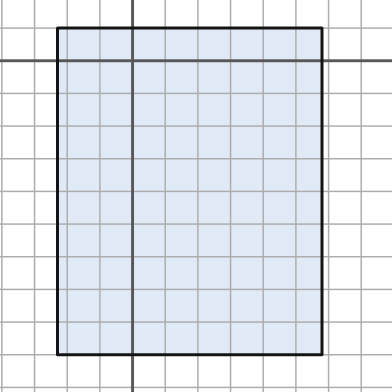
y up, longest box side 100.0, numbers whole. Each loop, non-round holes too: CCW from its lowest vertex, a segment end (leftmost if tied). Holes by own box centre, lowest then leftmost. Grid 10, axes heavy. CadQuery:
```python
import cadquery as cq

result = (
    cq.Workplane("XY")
    .moveTo(-23.0, -90.0)
    .lineTo(58.0, -90.0)
    .lineTo(58.0, 10.0)
    .lineTo(-23.0, 10.0)
    .close()
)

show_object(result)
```